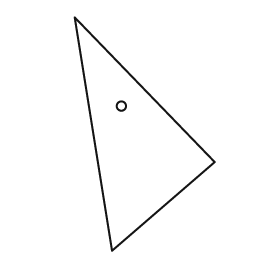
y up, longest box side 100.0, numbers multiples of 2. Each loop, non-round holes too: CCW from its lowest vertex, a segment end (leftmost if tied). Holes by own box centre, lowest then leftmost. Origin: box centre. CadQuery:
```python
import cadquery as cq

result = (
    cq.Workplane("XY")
    .moveTo(-14.0, -50.0)
    .lineTo(30.0, -12.0)
    .lineTo(-30.0, 50.0)
    .close()
    .moveTo(-10.0, 12.0)
    .circle(2.0)
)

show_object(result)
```